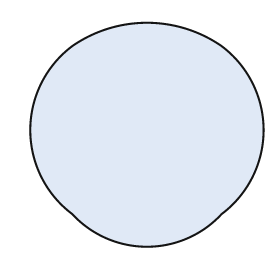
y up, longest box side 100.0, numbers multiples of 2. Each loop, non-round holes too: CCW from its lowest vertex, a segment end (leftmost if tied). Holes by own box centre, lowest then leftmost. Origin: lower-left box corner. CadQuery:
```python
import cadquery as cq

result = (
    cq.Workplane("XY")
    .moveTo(18.0, 14.0)
    .threePointArc((50.0, 0.0), (82.0, 14.0))
    .threePointArc((100.0, 50.0), (82.0, 86.0))
    .threePointArc((50.0, 96.0), (18.0, 86.0))
    .threePointArc((0.0, 50.0), (18.0, 14.0))
    .close()
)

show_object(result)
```